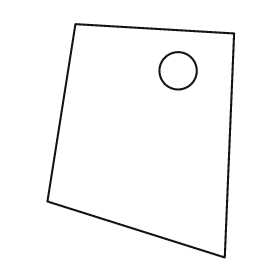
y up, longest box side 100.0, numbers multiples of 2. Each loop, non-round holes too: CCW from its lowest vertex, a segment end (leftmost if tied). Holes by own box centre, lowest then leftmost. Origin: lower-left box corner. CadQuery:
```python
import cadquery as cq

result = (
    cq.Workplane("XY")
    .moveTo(76.0, 0.0)
    .lineTo(80.0, 96.0)
    .lineTo(12.0, 100.0)
    .lineTo(0.0, 24.0)
    .close()
    .moveTo(56.0, 80.0)
    .circle(8.0)
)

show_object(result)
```